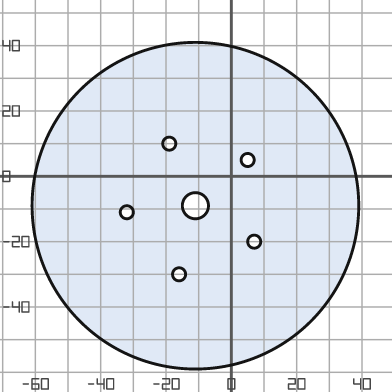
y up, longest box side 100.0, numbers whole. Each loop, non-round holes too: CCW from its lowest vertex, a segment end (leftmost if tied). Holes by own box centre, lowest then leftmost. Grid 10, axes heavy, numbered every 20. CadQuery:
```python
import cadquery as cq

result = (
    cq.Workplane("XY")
    .moveTo(-11.0, -9.0)
    .circle(50.0)
    .moveTo(-16.0, -30.0)
    .circle(2.0)
    .moveTo(7.0, -20.0)
    .circle(2.0)
    .moveTo(-32.0, -11.0)
    .circle(2.0)
    .moveTo(-11.0, -9.0)
    .circle(4.0)
    .moveTo(5.0, 5.0)
    .circle(2.0)
    .moveTo(-19.0, 10.0)
    .circle(2.0)
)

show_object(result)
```